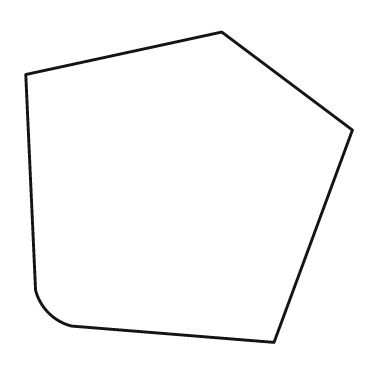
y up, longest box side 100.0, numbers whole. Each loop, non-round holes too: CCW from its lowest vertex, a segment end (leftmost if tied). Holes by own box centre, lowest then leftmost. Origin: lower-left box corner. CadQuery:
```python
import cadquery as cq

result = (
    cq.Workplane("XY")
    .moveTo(76.0, 0.0)
    .lineTo(100.0, 65.0)
    .lineTo(60.0, 95.0)
    .lineTo(0.0, 82.0)
    .lineTo(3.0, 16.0)
    .threePointArc((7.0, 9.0), (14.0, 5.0))
    .close()
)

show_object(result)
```